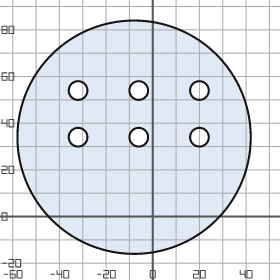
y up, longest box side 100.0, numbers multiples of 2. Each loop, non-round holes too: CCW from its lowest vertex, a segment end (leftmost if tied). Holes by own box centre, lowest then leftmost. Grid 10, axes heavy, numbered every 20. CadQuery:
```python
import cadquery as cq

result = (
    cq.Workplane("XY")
    .moveTo(-8.0, 34.0)
    .circle(50.0)
    .moveTo(-32.0, 34.0)
    .circle(4.0)
    .moveTo(-6.0, 34.0)
    .circle(4.0)
    .moveTo(20.0, 34.0)
    .circle(4.0)
    .moveTo(-32.0, 54.0)
    .circle(4.0)
    .moveTo(-6.0, 54.0)
    .circle(4.0)
    .moveTo(20.0, 54.0)
    .circle(4.0)
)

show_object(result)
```